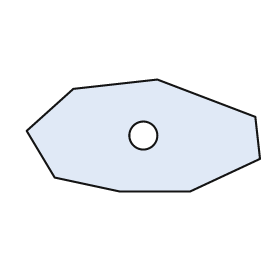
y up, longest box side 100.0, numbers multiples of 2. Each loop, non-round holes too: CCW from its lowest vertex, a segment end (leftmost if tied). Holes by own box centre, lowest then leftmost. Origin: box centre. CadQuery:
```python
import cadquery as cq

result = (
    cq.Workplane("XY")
    .moveTo(-10.0, -24.0)
    .lineTo(20.0, -24.0)
    .lineTo(50.0, -10.0)
    .lineTo(48.0, 8.0)
    .lineTo(6.0, 24.0)
    .lineTo(-30.0, 20.0)
    .lineTo(-50.0, 2.0)
    .lineTo(-38.0, -18.0)
    .close()
    .moveTo(0.0, 0.0)
    .circle(6.0)
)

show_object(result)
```